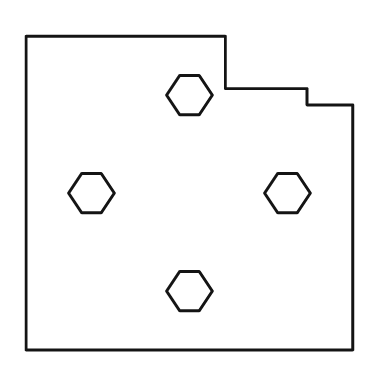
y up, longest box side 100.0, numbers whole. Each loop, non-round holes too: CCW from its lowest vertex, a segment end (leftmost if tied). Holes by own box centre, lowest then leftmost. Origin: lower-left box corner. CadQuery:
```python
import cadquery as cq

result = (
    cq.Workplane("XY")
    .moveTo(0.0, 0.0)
    .lineTo(100.0, 0.0)
    .lineTo(100.0, 75.0)
    .lineTo(86.0, 75.0)
    .lineTo(86.0, 80.0)
    .lineTo(61.0, 80.0)
    .lineTo(61.0, 96.0)
    .lineTo(0.0, 96.0)
    .close()
    .moveTo(47.0, 12.0)
    .lineTo(53.0, 12.0)
    .lineTo(57.0, 18.0)
    .lineTo(53.0, 24.0)
    .lineTo(47.0, 24.0)
    .lineTo(43.0, 18.0)
    .close()
    .moveTo(17.0, 42.0)
    .lineTo(23.0, 42.0)
    .lineTo(27.0, 48.0)
    .lineTo(23.0, 54.0)
    .lineTo(17.0, 54.0)
    .lineTo(13.0, 48.0)
    .close()
    .moveTo(77.0, 42.0)
    .lineTo(83.0, 42.0)
    .lineTo(87.0, 48.0)
    .lineTo(83.0, 54.0)
    .lineTo(77.0, 54.0)
    .lineTo(73.0, 48.0)
    .close()
    .moveTo(47.0, 72.0)
    .lineTo(53.0, 72.0)
    .lineTo(57.0, 78.0)
    .lineTo(53.0, 84.0)
    .lineTo(47.0, 84.0)
    .lineTo(43.0, 78.0)
    .close()
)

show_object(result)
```